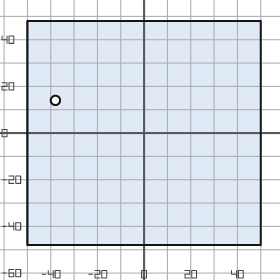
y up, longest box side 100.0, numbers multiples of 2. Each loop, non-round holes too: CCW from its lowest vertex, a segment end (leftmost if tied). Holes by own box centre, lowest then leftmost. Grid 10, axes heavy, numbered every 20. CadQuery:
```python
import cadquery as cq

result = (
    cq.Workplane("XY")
    .moveTo(-50.0, -48.0)
    .lineTo(50.0, -48.0)
    .lineTo(50.0, 48.0)
    .lineTo(-50.0, 48.0)
    .close()
    .moveTo(-38.0, 14.0)
    .circle(2.0)
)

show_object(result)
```